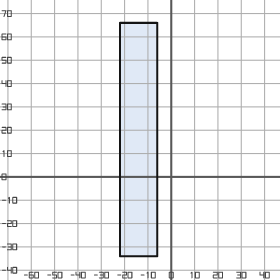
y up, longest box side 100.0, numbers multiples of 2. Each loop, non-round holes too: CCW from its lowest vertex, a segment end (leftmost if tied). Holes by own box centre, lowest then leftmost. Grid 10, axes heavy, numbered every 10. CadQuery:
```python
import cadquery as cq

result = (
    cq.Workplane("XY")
    .moveTo(-22.0, -34.0)
    .lineTo(-6.0, -34.0)
    .lineTo(-6.0, 66.0)
    .lineTo(-22.0, 66.0)
    .close()
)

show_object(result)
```